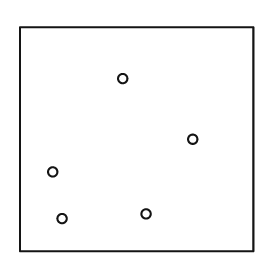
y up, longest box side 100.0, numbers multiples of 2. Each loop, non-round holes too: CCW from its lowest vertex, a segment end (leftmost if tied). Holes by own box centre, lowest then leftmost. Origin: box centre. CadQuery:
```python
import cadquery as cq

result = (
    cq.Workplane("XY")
    .moveTo(-50.0, -48.0)
    .lineTo(50.0, -48.0)
    .lineTo(50.0, 48.0)
    .lineTo(-50.0, 48.0)
    .close()
    .moveTo(-32.0, -34.0)
    .circle(2.0)
    .moveTo(4.0, -32.0)
    .circle(2.0)
    .moveTo(-36.0, -14.0)
    .circle(2.0)
    .moveTo(24.0, 0.0)
    .circle(2.0)
    .moveTo(-6.0, 26.0)
    .circle(2.0)
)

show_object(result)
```